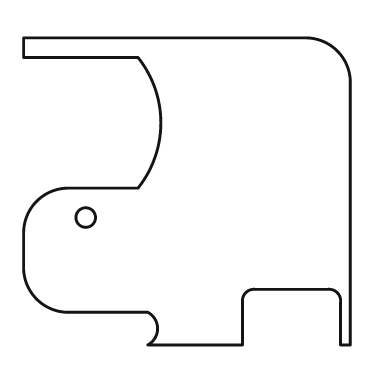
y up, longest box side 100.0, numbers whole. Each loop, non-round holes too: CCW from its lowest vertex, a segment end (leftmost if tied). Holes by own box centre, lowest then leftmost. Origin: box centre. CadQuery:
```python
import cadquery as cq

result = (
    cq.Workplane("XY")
    .moveTo(-12.0, -47.0)
    .lineTo(17.0, -47.0)
    .lineTo(17.0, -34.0)
    .threePointArc((18.0, -31.0), (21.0, -30.0))
    .lineTo(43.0, -30.0)
    .threePointArc((46.0, -31.0), (47.0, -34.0))
    .lineTo(47.0, -47.0)
    .lineTo(50.0, -47.0)
    .lineTo(50.0, 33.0)
    .threePointArc((46.0, 43.0), (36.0, 47.0))
    .lineTo(-50.0, 47.0)
    .lineTo(-50.0, 41.0)
    .lineTo(-15.0, 41.0)
    .threePointArc((-8.0, 21.0), (-15.0, 1.0))
    .lineTo(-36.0, 1.0)
    .threePointArc((-46.0, -3.0), (-50.0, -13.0))
    .lineTo(-50.0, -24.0)
    .threePointArc((-46.0, -33.0), (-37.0, -37.0))
    .lineTo(-12.0, -37.0)
    .threePointArc((-9.0, -42.0), (-12.0, -47.0))
    .close()
    .moveTo(-31.0, -8.0)
    .circle(3.0)
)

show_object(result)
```